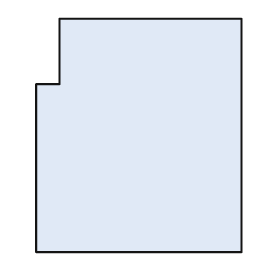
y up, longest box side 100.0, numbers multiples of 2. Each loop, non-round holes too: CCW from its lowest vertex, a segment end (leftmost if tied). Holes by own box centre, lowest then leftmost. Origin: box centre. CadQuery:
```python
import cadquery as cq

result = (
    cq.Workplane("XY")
    .moveTo(-44.0, -50.0)
    .lineTo(44.0, -50.0)
    .lineTo(44.0, 50.0)
    .lineTo(-34.0, 50.0)
    .lineTo(-34.0, 22.0)
    .lineTo(-44.0, 22.0)
    .close()
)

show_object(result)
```